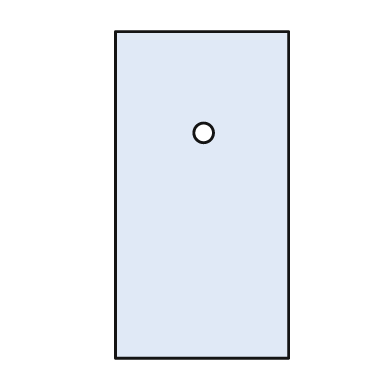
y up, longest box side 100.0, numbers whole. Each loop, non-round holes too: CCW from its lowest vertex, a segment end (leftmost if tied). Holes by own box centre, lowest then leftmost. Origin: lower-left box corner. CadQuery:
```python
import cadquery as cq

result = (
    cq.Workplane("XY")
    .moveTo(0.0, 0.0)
    .lineTo(53.0, 0.0)
    .lineTo(53.0, 100.0)
    .lineTo(0.0, 100.0)
    .close()
    .moveTo(27.0, 69.0)
    .circle(3.0)
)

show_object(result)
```